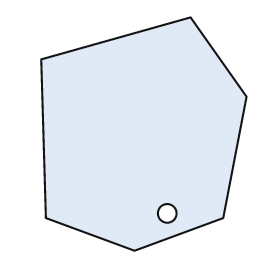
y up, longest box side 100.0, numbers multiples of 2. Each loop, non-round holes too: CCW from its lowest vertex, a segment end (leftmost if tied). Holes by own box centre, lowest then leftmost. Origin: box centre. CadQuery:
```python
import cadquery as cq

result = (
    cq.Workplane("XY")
    .moveTo(-4.0, -50.0)
    .lineTo(34.0, -36.0)
    .lineTo(44.0, 16.0)
    .lineTo(20.0, 50.0)
    .lineTo(-44.0, 32.0)
    .lineTo(-42.0, -36.0)
    .close()
    .moveTo(10.0, -34.0)
    .circle(4.0)
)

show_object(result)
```